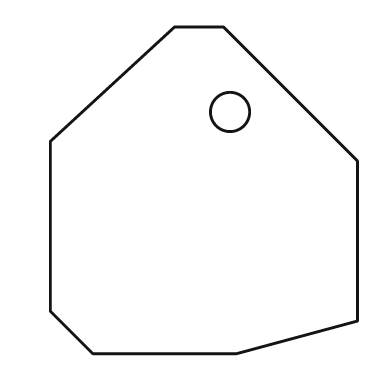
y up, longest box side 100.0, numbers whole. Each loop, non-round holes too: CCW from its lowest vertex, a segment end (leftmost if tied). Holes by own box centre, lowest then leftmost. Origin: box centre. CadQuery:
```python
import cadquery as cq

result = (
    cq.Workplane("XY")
    .moveTo(-34.0, -50.0)
    .lineTo(10.0, -50.0)
    .lineTo(47.0, -40.0)
    .lineTo(47.0, 9.0)
    .lineTo(6.0, 50.0)
    .lineTo(-9.0, 50.0)
    .lineTo(-47.0, 15.0)
    .lineTo(-47.0, -37.0)
    .close()
    .moveTo(8.0, 24.0)
    .circle(6.0)
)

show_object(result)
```